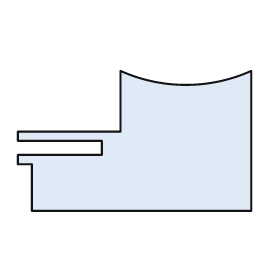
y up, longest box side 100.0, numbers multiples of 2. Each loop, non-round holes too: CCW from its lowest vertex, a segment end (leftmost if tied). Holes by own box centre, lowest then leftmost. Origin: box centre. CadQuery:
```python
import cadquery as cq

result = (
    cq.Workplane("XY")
    .moveTo(-44.0, -30.0)
    .lineTo(50.0, -30.0)
    .lineTo(50.0, 30.0)
    .threePointArc((22.0, 24.0), (-6.0, 30.0))
    .lineTo(-6.0, 4.0)
    .lineTo(-50.0, 4.0)
    .lineTo(-50.0, 0.0)
    .lineTo(-14.0, 0.0)
    .lineTo(-14.0, -6.0)
    .lineTo(-50.0, -6.0)
    .lineTo(-50.0, -10.0)
    .lineTo(-44.0, -10.0)
    .close()
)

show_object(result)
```